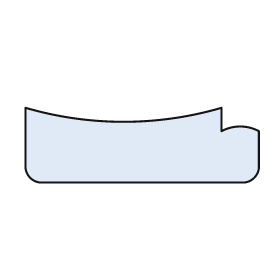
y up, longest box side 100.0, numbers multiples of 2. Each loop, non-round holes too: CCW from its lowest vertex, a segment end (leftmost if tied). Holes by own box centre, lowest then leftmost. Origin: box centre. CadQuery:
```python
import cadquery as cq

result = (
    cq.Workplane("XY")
    .moveTo(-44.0, -16.0)
    .lineTo(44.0, -16.0)
    .threePointArc((48.0, -14.0), (50.0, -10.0))
    .lineTo(50.0, 6.0)
    .threePointArc((42.0, 8.0), (34.0, 6.0))
    .lineTo(34.0, 16.0)
    .threePointArc((-8.0, 10.0), (-50.0, 16.0))
    .lineTo(-50.0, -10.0)
    .threePointArc((-48.0, -14.0), (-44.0, -16.0))
    .close()
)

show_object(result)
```